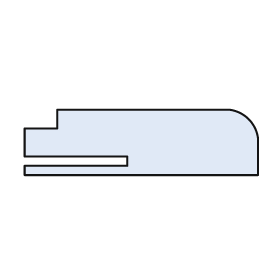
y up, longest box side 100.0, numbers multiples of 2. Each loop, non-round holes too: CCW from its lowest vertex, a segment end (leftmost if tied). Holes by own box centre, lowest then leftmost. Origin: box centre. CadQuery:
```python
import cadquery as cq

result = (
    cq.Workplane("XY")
    .moveTo(-50.0, -14.0)
    .lineTo(50.0, -14.0)
    .lineTo(50.0, 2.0)
    .threePointArc((46.0, 10.0), (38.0, 14.0))
    .lineTo(-36.0, 14.0)
    .lineTo(-36.0, 6.0)
    .lineTo(-50.0, 6.0)
    .lineTo(-50.0, -6.0)
    .lineTo(-6.0, -6.0)
    .lineTo(-6.0, -10.0)
    .lineTo(-50.0, -10.0)
    .close()
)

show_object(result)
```